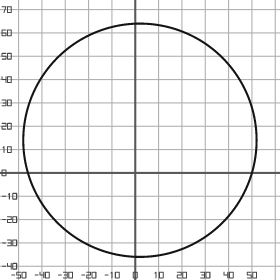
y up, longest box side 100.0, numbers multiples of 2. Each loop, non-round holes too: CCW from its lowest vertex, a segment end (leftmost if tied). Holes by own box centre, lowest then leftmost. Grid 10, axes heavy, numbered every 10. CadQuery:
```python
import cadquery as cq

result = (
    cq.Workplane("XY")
    .moveTo(2.0, 14.0)
    .circle(50.0)
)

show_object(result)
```